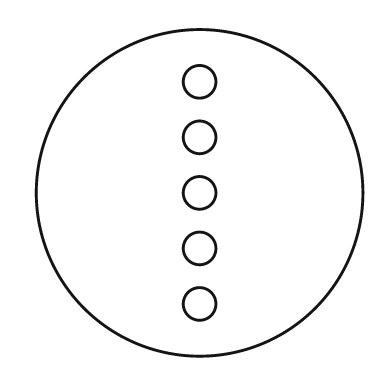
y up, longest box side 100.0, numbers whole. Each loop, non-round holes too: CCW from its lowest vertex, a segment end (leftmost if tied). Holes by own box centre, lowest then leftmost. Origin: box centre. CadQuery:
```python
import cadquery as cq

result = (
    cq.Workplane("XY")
    .moveTo(0.0, 0.0)
    .circle(50.0)
    .moveTo(0.0, -34.0)
    .circle(5.0)
    .moveTo(0.0, -17.0)
    .circle(5.0)
    .moveTo(0.0, 0.0)
    .circle(5.0)
    .moveTo(0.0, 17.0)
    .circle(5.0)
    .moveTo(0.0, 34.0)
    .circle(5.0)
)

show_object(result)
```